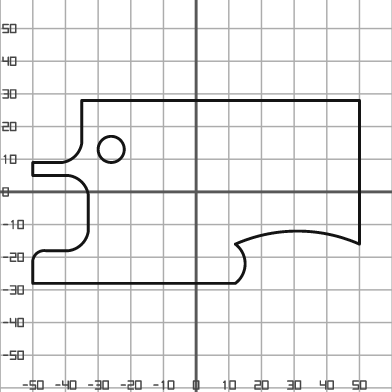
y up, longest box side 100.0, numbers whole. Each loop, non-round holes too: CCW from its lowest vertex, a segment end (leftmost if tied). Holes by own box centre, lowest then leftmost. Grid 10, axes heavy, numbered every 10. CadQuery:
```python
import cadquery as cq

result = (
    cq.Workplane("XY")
    .moveTo(-50.0, -28.0)
    .lineTo(12.0, -28.0)
    .threePointArc((15.0, -22.0), (12.0, -16.0))
    .threePointArc((31.0, -12.0), (50.0, -16.0))
    .lineTo(50.0, 28.0)
    .lineTo(-35.0, 28.0)
    .lineTo(-35.0, 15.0)
    .threePointArc((-37.0, 11.0), (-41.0, 9.0))
    .lineTo(-50.0, 9.0)
    .lineTo(-50.0, 5.0)
    .lineTo(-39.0, 5.0)
    .threePointArc((-35.0, 3.0), (-33.0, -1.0))
    .lineTo(-33.0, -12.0)
    .threePointArc((-35.0, -16.0), (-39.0, -18.0))
    .lineTo(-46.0, -18.0)
    .threePointArc((-49.0, -19.0), (-50.0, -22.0))
    .close()
    .moveTo(-26.0, 13.0)
    .circle(4.0)
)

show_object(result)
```